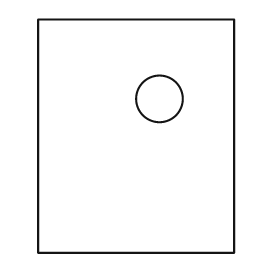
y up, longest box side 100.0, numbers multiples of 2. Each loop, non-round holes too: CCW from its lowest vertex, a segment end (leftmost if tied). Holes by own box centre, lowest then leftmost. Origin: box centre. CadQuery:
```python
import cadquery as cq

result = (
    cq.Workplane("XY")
    .moveTo(-42.0, -50.0)
    .lineTo(42.0, -50.0)
    .lineTo(42.0, 50.0)
    .lineTo(-42.0, 50.0)
    .close()
    .moveTo(10.0, 16.0)
    .circle(10.0)
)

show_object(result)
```